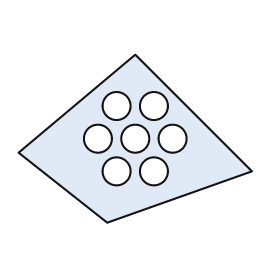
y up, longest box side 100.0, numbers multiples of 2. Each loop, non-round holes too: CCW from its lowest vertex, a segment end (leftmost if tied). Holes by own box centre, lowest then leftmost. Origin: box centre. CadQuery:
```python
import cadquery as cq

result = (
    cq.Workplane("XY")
    .moveTo(-12.0, -36.0)
    .lineTo(50.0, -14.0)
    .lineTo(0.0, 36.0)
    .lineTo(-50.0, -6.0)
    .close()
    .moveTo(-8.0, -14.0)
    .circle(6.0)
    .moveTo(8.0, -14.0)
    .circle(6.0)
    .moveTo(-16.0, 0.0)
    .circle(6.0)
    .moveTo(0.0, 0.0)
    .circle(6.0)
    .moveTo(16.0, 0.0)
    .circle(6.0)
    .moveTo(-8.0, 14.0)
    .circle(6.0)
    .moveTo(8.0, 14.0)
    .circle(6.0)
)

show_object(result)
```